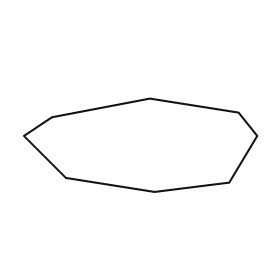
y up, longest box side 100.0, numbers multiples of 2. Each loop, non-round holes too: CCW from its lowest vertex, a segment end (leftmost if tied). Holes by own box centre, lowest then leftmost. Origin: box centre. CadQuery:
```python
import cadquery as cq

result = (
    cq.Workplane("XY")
    .moveTo(6.0, -20.0)
    .lineTo(38.0, -16.0)
    .lineTo(50.0, 4.0)
    .lineTo(42.0, 14.0)
    .lineTo(4.0, 20.0)
    .lineTo(-38.0, 12.0)
    .lineTo(-50.0, 4.0)
    .lineTo(-32.0, -14.0)
    .close()
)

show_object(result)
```